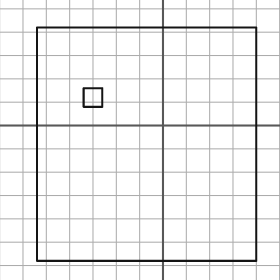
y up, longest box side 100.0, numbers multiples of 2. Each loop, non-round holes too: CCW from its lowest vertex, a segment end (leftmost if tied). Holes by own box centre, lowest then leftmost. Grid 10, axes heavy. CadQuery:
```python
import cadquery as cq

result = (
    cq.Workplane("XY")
    .moveTo(-54.0, -58.0)
    .lineTo(40.0, -58.0)
    .lineTo(40.0, 42.0)
    .lineTo(-54.0, 42.0)
    .close()
    .moveTo(-34.0, 8.0)
    .lineTo(-26.0, 8.0)
    .lineTo(-26.0, 16.0)
    .lineTo(-34.0, 16.0)
    .close()
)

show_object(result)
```